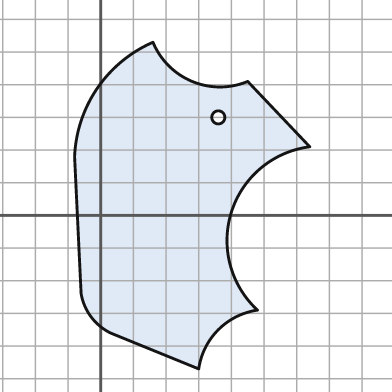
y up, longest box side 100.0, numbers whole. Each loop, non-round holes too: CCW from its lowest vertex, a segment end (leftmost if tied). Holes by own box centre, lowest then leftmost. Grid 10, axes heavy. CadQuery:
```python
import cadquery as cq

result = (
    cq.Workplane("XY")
    .moveTo(30.0, -47.0)
    .threePointArc((36.0, -35.0), (48.0, -29.0))
    .threePointArc((40.0, 1.0), (64.0, 21.0))
    .lineTo(45.0, 41.0)
    .threePointArc((28.0, 41.0), (16.0, 53.0))
    .threePointArc((-1.0, 39.0), (-8.0, 18.0))
    .lineTo(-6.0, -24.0)
    .threePointArc((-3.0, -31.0), (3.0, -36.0))
    .close()
    .moveTo(36.0, 30.0)
    .circle(2.0)
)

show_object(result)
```